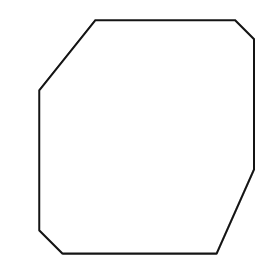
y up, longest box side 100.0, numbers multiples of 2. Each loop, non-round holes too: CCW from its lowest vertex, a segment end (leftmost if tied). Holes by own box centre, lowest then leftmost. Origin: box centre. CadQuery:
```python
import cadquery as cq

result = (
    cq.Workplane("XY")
    .moveTo(-36.0, -50.0)
    .lineTo(30.0, -50.0)
    .lineTo(46.0, -14.0)
    .lineTo(46.0, 42.0)
    .lineTo(38.0, 50.0)
    .lineTo(-22.0, 50.0)
    .lineTo(-46.0, 20.0)
    .lineTo(-46.0, -40.0)
    .close()
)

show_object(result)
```